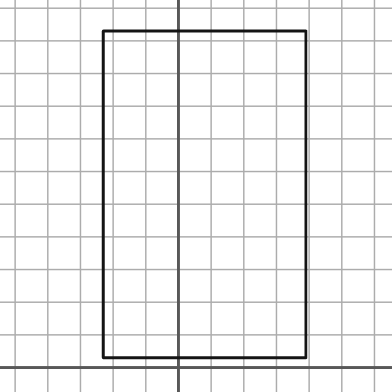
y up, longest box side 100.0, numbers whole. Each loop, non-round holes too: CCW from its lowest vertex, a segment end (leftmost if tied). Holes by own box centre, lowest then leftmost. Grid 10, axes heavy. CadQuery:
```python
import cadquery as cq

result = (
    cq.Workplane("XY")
    .moveTo(-23.0, 3.0)
    .lineTo(39.0, 3.0)
    .lineTo(39.0, 103.0)
    .lineTo(-23.0, 103.0)
    .close()
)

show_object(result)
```